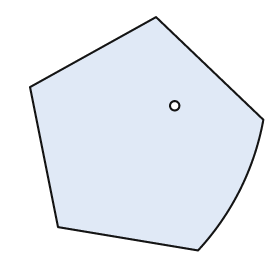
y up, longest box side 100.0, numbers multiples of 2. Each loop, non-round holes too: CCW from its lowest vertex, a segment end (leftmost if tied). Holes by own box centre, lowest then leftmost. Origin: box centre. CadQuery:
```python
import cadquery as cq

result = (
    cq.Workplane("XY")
    .moveTo(22.0, -50.0)
    .threePointArc((40.0, -24.0), (50.0, 6.0))
    .lineTo(4.0, 50.0)
    .lineTo(-50.0, 20.0)
    .lineTo(-38.0, -40.0)
    .close()
    .moveTo(12.0, 12.0)
    .circle(2.0)
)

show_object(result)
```